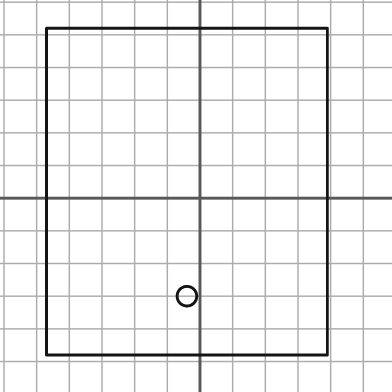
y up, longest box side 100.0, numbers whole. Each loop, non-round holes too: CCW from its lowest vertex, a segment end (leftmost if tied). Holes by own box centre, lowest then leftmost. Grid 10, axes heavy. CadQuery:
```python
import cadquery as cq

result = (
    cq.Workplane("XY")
    .moveTo(-47.0, -48.0)
    .lineTo(39.0, -48.0)
    .lineTo(39.0, 52.0)
    .lineTo(-47.0, 52.0)
    .close()
    .moveTo(-4.0, -30.0)
    .circle(3.0)
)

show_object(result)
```